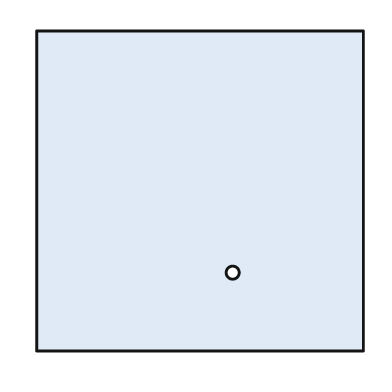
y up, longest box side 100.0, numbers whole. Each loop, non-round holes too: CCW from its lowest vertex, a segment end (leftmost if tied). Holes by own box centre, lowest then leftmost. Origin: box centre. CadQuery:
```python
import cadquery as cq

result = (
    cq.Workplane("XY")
    .moveTo(-50.0, -49.0)
    .lineTo(50.0, -49.0)
    .lineTo(50.0, 49.0)
    .lineTo(-50.0, 49.0)
    .close()
    .moveTo(10.0, -25.0)
    .circle(2.0)
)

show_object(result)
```